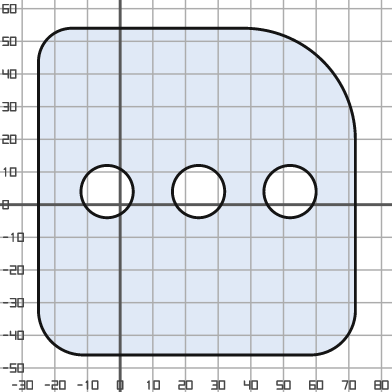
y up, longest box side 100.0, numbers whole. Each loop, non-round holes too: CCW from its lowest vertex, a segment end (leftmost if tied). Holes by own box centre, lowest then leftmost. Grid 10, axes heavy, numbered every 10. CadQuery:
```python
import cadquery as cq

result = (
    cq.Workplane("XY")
    .moveTo(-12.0, -46.0)
    .lineTo(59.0, -46.0)
    .threePointArc((68.0, -42.0), (72.0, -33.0))
    .lineTo(72.0, 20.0)
    .threePointArc((62.0, 44.0), (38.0, 54.0))
    .lineTo(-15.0, 54.0)
    .threePointArc((-22.0, 51.0), (-25.0, 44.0))
    .lineTo(-25.0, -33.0)
    .threePointArc((-21.0, -42.0), (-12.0, -46.0))
    .close()
    .moveTo(-4.0, 4.0)
    .circle(8.0)
    .moveTo(24.0, 4.0)
    .circle(8.0)
    .moveTo(52.0, 4.0)
    .circle(8.0)
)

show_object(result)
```